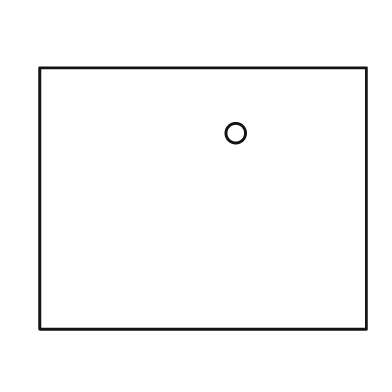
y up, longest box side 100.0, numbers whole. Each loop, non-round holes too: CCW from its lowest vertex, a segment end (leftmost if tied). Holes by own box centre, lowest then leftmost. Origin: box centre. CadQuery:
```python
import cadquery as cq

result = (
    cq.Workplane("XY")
    .moveTo(-50.0, -40.0)
    .lineTo(50.0, -40.0)
    .lineTo(50.0, 40.0)
    .lineTo(-50.0, 40.0)
    .close()
    .moveTo(10.0, 20.0)
    .circle(3.0)
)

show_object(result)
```